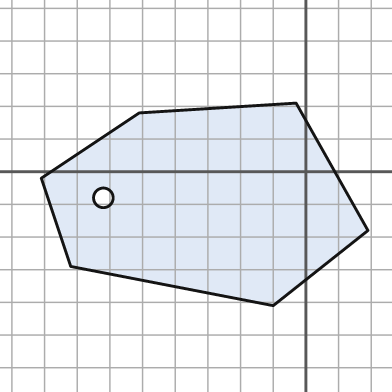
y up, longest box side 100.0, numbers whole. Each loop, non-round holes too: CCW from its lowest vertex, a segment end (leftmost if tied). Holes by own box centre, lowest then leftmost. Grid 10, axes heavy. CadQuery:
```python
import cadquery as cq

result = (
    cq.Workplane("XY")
    .moveTo(-10.0, -41.0)
    .lineTo(19.0, -18.0)
    .lineTo(-3.0, 21.0)
    .lineTo(-51.0, 18.0)
    .lineTo(-81.0, -2.0)
    .lineTo(-72.0, -29.0)
    .close()
    .moveTo(-62.0, -8.0)
    .circle(3.0)
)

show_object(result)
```